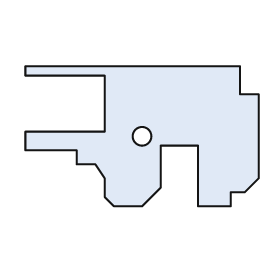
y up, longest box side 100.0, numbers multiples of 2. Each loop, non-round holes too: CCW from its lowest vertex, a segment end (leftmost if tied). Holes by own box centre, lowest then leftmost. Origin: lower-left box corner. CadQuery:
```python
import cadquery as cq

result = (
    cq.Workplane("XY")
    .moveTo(38.0, 0.0)
    .lineTo(50.0, 0.0)
    .lineTo(58.0, 8.0)
    .lineTo(58.0, 26.0)
    .lineTo(74.0, 26.0)
    .lineTo(74.0, 0.0)
    .lineTo(88.0, 0.0)
    .lineTo(88.0, 6.0)
    .lineTo(94.0, 6.0)
    .lineTo(100.0, 12.0)
    .lineTo(100.0, 48.0)
    .lineTo(92.0, 48.0)
    .lineTo(92.0, 60.0)
    .lineTo(0.0, 60.0)
    .lineTo(0.0, 56.0)
    .lineTo(34.0, 56.0)
    .lineTo(34.0, 32.0)
    .lineTo(0.0, 32.0)
    .lineTo(0.0, 24.0)
    .lineTo(22.0, 24.0)
    .lineTo(22.0, 18.0)
    .lineTo(30.0, 18.0)
    .lineTo(34.0, 12.0)
    .lineTo(34.0, 4.0)
    .close()
    .moveTo(50.0, 30.0)
    .circle(4.0)
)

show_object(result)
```